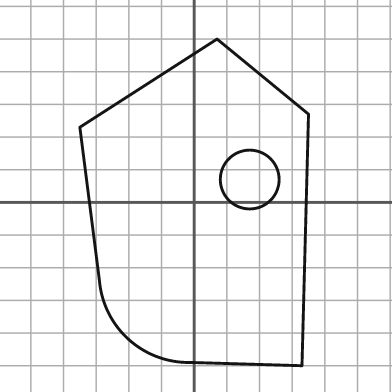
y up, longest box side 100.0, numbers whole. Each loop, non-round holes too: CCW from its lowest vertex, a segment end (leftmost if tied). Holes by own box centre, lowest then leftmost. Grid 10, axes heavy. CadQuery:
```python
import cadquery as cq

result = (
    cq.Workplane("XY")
    .moveTo(33.0, -50.0)
    .lineTo(35.0, 27.0)
    .lineTo(7.0, 50.0)
    .lineTo(-35.0, 23.0)
    .lineTo(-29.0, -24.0)
    .threePointArc((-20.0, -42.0), (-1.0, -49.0))
    .close()
    .moveTo(17.0, 7.0)
    .circle(9.0)
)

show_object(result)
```